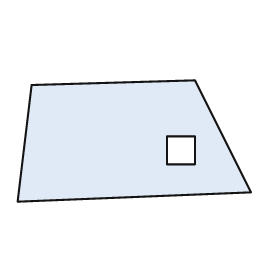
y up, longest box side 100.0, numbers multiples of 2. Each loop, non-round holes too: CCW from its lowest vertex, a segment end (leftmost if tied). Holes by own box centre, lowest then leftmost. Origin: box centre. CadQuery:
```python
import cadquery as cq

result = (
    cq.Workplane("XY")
    .moveTo(-50.0, -26.0)
    .lineTo(50.0, -22.0)
    .lineTo(26.0, 26.0)
    .lineTo(-44.0, 24.0)
    .close()
    .moveTo(14.0, -10.0)
    .lineTo(26.0, -10.0)
    .lineTo(26.0, 2.0)
    .lineTo(14.0, 2.0)
    .close()
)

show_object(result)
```